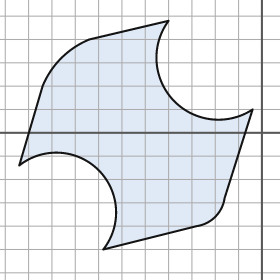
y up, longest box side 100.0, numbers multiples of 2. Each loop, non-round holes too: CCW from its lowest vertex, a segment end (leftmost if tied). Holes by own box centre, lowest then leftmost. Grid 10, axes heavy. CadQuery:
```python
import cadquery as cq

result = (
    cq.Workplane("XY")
    .moveTo(-68.0, -50.0)
    .lineTo(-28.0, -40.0)
    .threePointArc((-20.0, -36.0), (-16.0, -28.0))
    .lineTo(-4.0, 10.0)
    .threePointArc((-38.0, 14.0), (-40.0, 48.0))
    .lineTo(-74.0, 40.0)
    .threePointArc((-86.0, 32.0), (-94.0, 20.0))
    .lineTo(-104.0, -14.0)
    .threePointArc((-70.0, -16.0), (-68.0, -50.0))
    .close()
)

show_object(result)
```